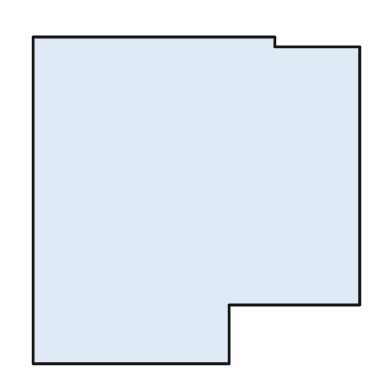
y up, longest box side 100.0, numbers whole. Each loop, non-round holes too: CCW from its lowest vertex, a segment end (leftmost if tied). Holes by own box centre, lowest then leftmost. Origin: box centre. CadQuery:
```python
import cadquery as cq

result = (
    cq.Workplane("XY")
    .moveTo(-50.0, -50.0)
    .lineTo(10.0, -50.0)
    .lineTo(10.0, -32.0)
    .lineTo(50.0, -32.0)
    .lineTo(50.0, 47.0)
    .lineTo(24.0, 47.0)
    .lineTo(24.0, 50.0)
    .lineTo(-50.0, 50.0)
    .close()
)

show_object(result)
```